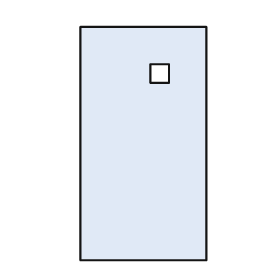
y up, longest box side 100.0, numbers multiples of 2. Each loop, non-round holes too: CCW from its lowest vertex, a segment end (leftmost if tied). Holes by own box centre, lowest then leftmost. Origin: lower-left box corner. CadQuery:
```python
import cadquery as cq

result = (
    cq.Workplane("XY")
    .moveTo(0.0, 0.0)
    .lineTo(54.0, 0.0)
    .lineTo(54.0, 100.0)
    .lineTo(0.0, 100.0)
    .close()
    .moveTo(30.0, 76.0)
    .lineTo(38.0, 76.0)
    .lineTo(38.0, 84.0)
    .lineTo(30.0, 84.0)
    .close()
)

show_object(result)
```